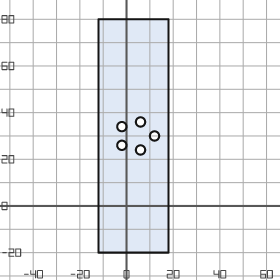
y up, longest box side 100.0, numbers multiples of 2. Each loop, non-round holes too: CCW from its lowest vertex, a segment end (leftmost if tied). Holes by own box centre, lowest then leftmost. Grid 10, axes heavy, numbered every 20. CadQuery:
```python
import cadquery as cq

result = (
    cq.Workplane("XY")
    .moveTo(-12.0, -20.0)
    .lineTo(18.0, -20.0)
    .lineTo(18.0, 80.0)
    .lineTo(-12.0, 80.0)
    .close()
    .moveTo(6.0, 24.0)
    .circle(2.0)
    .moveTo(-2.0, 26.0)
    .circle(2.0)
    .moveTo(12.0, 30.0)
    .circle(2.0)
    .moveTo(-2.0, 34.0)
    .circle(2.0)
    .moveTo(6.0, 36.0)
    .circle(2.0)
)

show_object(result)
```